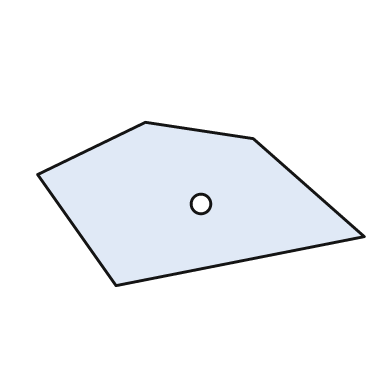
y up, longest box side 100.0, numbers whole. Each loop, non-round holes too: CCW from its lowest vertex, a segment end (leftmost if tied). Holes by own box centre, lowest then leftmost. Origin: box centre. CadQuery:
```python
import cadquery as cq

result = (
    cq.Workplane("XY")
    .moveTo(-26.0, -25.0)
    .lineTo(50.0, -10.0)
    .lineTo(16.0, 20.0)
    .lineTo(-17.0, 25.0)
    .lineTo(-50.0, 9.0)
    .close()
    .moveTo(0.0, 0.0)
    .circle(3.0)
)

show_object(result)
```